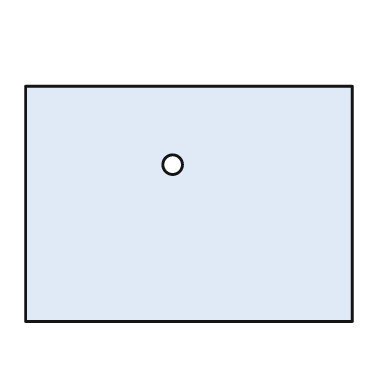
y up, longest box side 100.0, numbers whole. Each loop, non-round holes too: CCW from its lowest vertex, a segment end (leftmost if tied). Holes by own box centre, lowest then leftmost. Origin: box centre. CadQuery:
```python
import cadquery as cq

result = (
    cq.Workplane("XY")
    .moveTo(-50.0, -36.0)
    .lineTo(50.0, -36.0)
    .lineTo(50.0, 36.0)
    .lineTo(-50.0, 36.0)
    .close()
    .moveTo(-5.0, 12.0)
    .circle(3.0)
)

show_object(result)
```